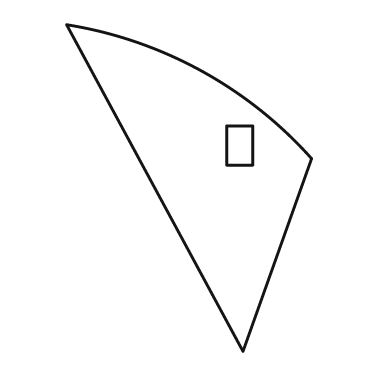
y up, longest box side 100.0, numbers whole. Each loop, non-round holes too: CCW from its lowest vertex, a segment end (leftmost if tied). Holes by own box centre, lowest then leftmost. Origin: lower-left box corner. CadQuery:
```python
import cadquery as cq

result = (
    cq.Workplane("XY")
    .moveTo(54.0, 0.0)
    .lineTo(75.0, 59.0)
    .threePointArc((41.0, 86.0), (0.0, 100.0))
    .close()
    .moveTo(49.0, 57.0)
    .lineTo(57.0, 57.0)
    .lineTo(57.0, 69.0)
    .lineTo(49.0, 69.0)
    .close()
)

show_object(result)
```